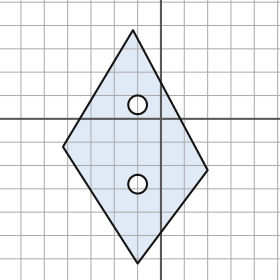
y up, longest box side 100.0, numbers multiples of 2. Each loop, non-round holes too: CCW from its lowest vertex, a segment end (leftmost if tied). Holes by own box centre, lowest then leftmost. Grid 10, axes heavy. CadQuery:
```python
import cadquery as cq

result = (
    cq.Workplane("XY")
    .moveTo(-10.0, -62.0)
    .lineTo(20.0, -22.0)
    .lineTo(-12.0, 38.0)
    .lineTo(-42.0, -12.0)
    .close()
    .moveTo(-10.0, -28.0)
    .circle(4.0)
    .moveTo(-10.0, 6.0)
    .circle(4.0)
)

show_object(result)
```